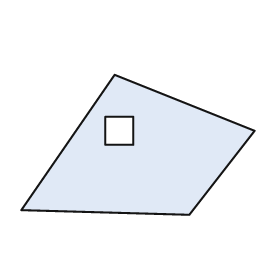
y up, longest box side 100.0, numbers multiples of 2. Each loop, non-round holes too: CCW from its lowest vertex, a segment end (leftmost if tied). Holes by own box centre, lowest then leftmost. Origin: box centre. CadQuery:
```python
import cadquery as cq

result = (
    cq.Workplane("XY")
    .moveTo(22.0, -30.0)
    .lineTo(50.0, 6.0)
    .lineTo(-10.0, 30.0)
    .lineTo(-50.0, -28.0)
    .close()
    .moveTo(-14.0, 0.0)
    .lineTo(-2.0, 0.0)
    .lineTo(-2.0, 12.0)
    .lineTo(-14.0, 12.0)
    .close()
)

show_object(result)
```